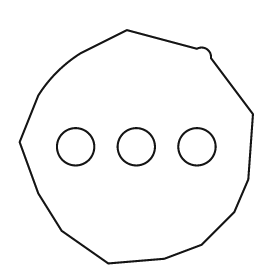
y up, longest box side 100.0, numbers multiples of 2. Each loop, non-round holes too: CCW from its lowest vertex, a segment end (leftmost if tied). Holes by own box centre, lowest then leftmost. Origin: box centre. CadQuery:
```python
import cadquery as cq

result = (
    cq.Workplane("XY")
    .moveTo(-12.0, -50.0)
    .lineTo(12.0, -48.0)
    .lineTo(28.0, -42.0)
    .lineTo(42.0, -28.0)
    .lineTo(48.0, -14.0)
    .lineTo(50.0, 14.0)
    .lineTo(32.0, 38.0)
    .threePointArc((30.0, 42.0), (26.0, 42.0))
    .lineTo(-4.0, 50.0)
    .lineTo(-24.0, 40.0)
    .threePointArc((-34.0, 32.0), (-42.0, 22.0))
    .lineTo(-50.0, 2.0)
    .lineTo(-42.0, -20.0)
    .lineTo(-32.0, -36.0)
    .close()
    .moveTo(-26.0, 0.0)
    .circle(8.0)
    .moveTo(0.0, 0.0)
    .circle(8.0)
    .moveTo(26.0, 0.0)
    .circle(8.0)
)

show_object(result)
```